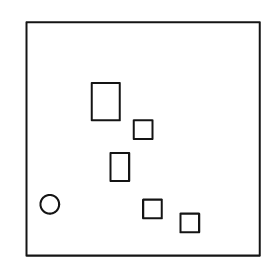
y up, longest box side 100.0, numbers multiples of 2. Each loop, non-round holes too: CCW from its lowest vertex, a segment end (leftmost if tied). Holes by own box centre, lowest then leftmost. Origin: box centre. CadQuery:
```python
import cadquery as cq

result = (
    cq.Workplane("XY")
    .moveTo(-50.0, -50.0)
    .lineTo(50.0, -50.0)
    .lineTo(50.0, 50.0)
    .lineTo(-50.0, 50.0)
    .close()
    .moveTo(16.0, -40.0)
    .lineTo(24.0, -40.0)
    .lineTo(24.0, -32.0)
    .lineTo(16.0, -32.0)
    .close()
    .moveTo(0.0, -34.0)
    .lineTo(8.0, -34.0)
    .lineTo(8.0, -26.0)
    .lineTo(0.0, -26.0)
    .close()
    .moveTo(-40.0, -28.0)
    .circle(4.0)
    .moveTo(-14.0, -18.0)
    .lineTo(-6.0, -18.0)
    .lineTo(-6.0, -6.0)
    .lineTo(-14.0, -6.0)
    .close()
    .moveTo(-4.0, 0.0)
    .lineTo(4.0, 0.0)
    .lineTo(4.0, 8.0)
    .lineTo(-4.0, 8.0)
    .close()
    .moveTo(-22.0, 8.0)
    .lineTo(-10.0, 8.0)
    .lineTo(-10.0, 24.0)
    .lineTo(-22.0, 24.0)
    .close()
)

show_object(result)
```